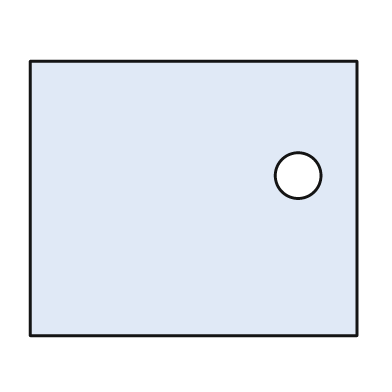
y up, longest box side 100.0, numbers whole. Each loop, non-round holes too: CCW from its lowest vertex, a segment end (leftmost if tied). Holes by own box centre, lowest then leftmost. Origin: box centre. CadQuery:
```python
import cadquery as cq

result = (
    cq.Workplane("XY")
    .moveTo(-50.0, -42.0)
    .lineTo(50.0, -42.0)
    .lineTo(50.0, 42.0)
    .lineTo(-50.0, 42.0)
    .close()
    .moveTo(32.0, 7.0)
    .circle(7.0)
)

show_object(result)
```